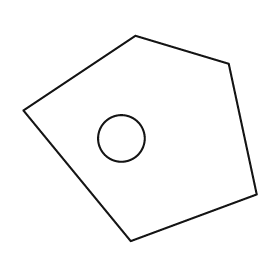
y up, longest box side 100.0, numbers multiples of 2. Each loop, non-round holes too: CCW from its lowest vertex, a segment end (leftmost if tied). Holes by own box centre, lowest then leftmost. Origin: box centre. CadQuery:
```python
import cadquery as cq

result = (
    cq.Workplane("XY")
    .moveTo(-4.0, -44.0)
    .lineTo(50.0, -24.0)
    .lineTo(38.0, 32.0)
    .lineTo(-2.0, 44.0)
    .lineTo(-50.0, 12.0)
    .close()
    .moveTo(-8.0, 0.0)
    .circle(10.0)
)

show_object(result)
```